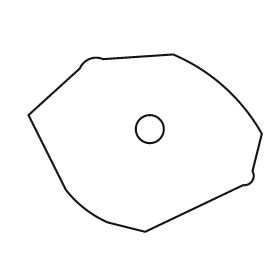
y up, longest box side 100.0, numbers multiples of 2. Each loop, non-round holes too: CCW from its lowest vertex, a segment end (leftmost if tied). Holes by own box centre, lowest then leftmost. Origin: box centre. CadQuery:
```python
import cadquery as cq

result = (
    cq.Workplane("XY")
    .moveTo(0.0, -38.0)
    .lineTo(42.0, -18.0)
    .threePointArc((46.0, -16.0), (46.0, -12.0))
    .lineTo(50.0, 4.0)
    .threePointArc((34.0, 24.0), (12.0, 38.0))
    .lineTo(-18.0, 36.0)
    .threePointArc((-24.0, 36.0), (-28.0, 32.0))
    .lineTo(-50.0, 12.0)
    .lineTo(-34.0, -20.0)
    .threePointArc((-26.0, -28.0), (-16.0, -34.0))
    .close()
    .moveTo(2.0, 6.0)
    .circle(6.0)
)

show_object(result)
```